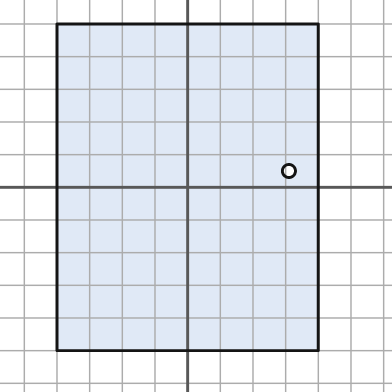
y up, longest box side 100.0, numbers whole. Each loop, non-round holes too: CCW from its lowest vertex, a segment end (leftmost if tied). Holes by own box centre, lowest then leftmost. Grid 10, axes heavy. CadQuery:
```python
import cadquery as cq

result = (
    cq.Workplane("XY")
    .moveTo(-40.0, -50.0)
    .lineTo(40.0, -50.0)
    .lineTo(40.0, 50.0)
    .lineTo(-40.0, 50.0)
    .close()
    .moveTo(31.0, 5.0)
    .circle(2.0)
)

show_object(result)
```